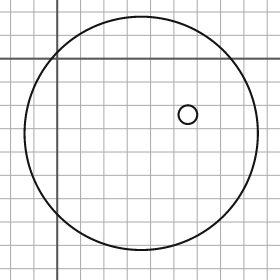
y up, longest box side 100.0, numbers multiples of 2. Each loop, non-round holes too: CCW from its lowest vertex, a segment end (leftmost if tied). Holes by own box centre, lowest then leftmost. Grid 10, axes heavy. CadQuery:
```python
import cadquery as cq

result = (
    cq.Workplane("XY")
    .moveTo(36.0, -32.0)
    .circle(50.0)
    .moveTo(56.0, -24.0)
    .circle(4.0)
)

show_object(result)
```